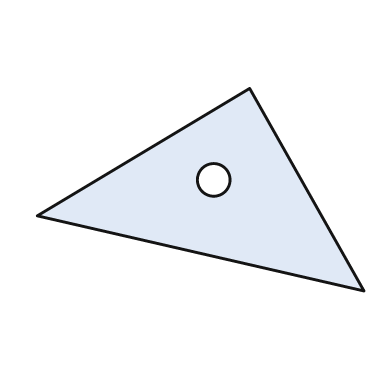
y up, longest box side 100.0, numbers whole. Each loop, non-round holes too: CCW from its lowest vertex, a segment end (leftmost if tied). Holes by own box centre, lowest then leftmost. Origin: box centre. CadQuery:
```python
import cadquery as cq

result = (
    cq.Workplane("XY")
    .moveTo(50.0, -31.0)
    .lineTo(15.0, 31.0)
    .lineTo(-50.0, -8.0)
    .close()
    .moveTo(4.0, 3.0)
    .circle(5.0)
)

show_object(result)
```